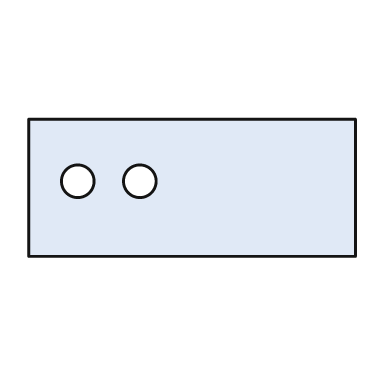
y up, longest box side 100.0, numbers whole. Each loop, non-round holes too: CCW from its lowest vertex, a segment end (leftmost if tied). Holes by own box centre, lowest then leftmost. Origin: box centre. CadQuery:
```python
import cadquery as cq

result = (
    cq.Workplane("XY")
    .moveTo(-50.0, -21.0)
    .lineTo(50.0, -21.0)
    .lineTo(50.0, 21.0)
    .lineTo(-50.0, 21.0)
    .close()
    .moveTo(-35.0, 2.0)
    .circle(5.0)
    .moveTo(-16.0, 2.0)
    .circle(5.0)
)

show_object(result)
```